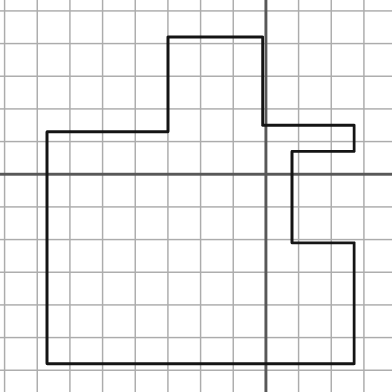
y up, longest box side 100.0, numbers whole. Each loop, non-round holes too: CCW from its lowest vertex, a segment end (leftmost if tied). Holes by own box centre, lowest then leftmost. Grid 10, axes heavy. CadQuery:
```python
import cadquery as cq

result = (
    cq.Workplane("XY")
    .moveTo(-67.0, -58.0)
    .lineTo(27.0, -58.0)
    .lineTo(27.0, -21.0)
    .lineTo(8.0, -21.0)
    .lineTo(8.0, 7.0)
    .lineTo(27.0, 7.0)
    .lineTo(27.0, 15.0)
    .lineTo(-1.0, 15.0)
    .lineTo(-1.0, 42.0)
    .lineTo(-30.0, 42.0)
    .lineTo(-30.0, 13.0)
    .lineTo(-67.0, 13.0)
    .close()
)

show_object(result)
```